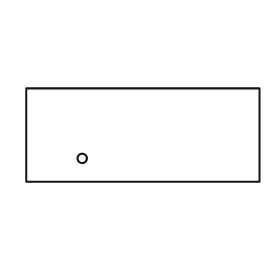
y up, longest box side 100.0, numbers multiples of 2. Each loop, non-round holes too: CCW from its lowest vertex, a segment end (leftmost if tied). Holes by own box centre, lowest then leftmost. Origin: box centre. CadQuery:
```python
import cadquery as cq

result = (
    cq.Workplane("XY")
    .moveTo(-50.0, -20.0)
    .lineTo(50.0, -20.0)
    .lineTo(50.0, 20.0)
    .lineTo(-50.0, 20.0)
    .close()
    .moveTo(-26.0, -10.0)
    .circle(2.0)
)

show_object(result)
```